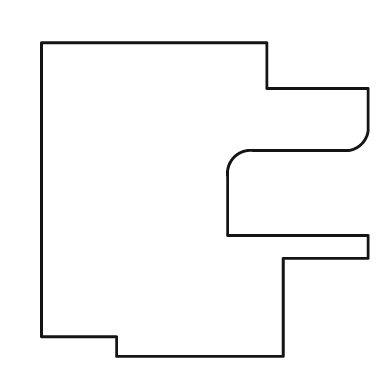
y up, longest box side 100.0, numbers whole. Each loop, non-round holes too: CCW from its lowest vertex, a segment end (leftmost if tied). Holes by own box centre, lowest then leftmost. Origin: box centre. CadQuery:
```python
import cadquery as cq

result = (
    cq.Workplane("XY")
    .moveTo(-27.0, -48.0)
    .lineTo(24.0, -48.0)
    .lineTo(24.0, -18.0)
    .lineTo(50.0, -18.0)
    .lineTo(50.0, -11.0)
    .lineTo(7.0, -11.0)
    .lineTo(7.0, 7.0)
    .threePointArc((9.0, 13.0), (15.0, 15.0))
    .lineTo(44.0, 15.0)
    .threePointArc((48.0, 17.0), (50.0, 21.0))
    .lineTo(50.0, 34.0)
    .lineTo(19.0, 34.0)
    .lineTo(19.0, 48.0)
    .lineTo(-50.0, 48.0)
    .lineTo(-50.0, -42.0)
    .lineTo(-27.0, -42.0)
    .close()
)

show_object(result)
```